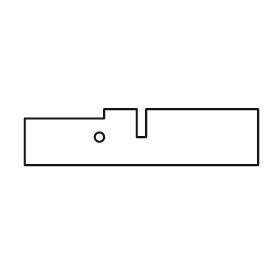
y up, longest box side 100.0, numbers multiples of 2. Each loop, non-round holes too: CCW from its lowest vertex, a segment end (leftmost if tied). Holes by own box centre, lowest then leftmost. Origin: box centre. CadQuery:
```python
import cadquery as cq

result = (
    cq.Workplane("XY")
    .moveTo(-50.0, -12.0)
    .lineTo(50.0, -12.0)
    .lineTo(50.0, 12.0)
    .lineTo(2.0, 12.0)
    .lineTo(2.0, 0.0)
    .lineTo(-2.0, 0.0)
    .lineTo(-2.0, 12.0)
    .lineTo(-16.0, 12.0)
    .lineTo(-16.0, 8.0)
    .lineTo(-50.0, 8.0)
    .close()
    .moveTo(-18.0, 0.0)
    .circle(2.0)
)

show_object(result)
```